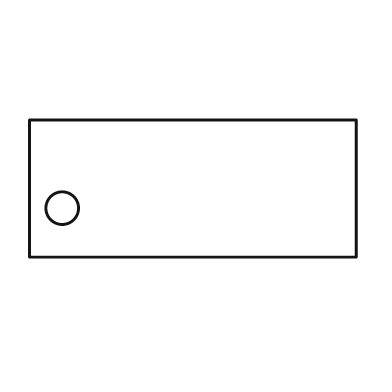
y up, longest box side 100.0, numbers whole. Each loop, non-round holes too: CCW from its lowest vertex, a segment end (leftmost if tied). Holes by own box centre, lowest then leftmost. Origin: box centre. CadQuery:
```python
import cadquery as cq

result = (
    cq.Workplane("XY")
    .moveTo(-50.0, -21.0)
    .lineTo(50.0, -21.0)
    .lineTo(50.0, 21.0)
    .lineTo(-50.0, 21.0)
    .close()
    .moveTo(-40.0, -6.0)
    .circle(5.0)
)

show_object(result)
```